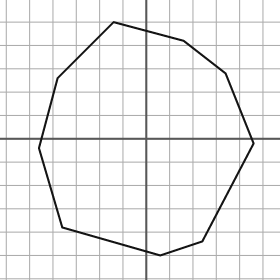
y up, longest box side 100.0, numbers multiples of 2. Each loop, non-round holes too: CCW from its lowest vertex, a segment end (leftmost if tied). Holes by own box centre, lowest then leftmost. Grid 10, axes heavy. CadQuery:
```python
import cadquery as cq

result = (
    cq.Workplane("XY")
    .moveTo(6.0, -50.0)
    .lineTo(24.0, -44.0)
    .lineTo(46.0, -2.0)
    .lineTo(34.0, 28.0)
    .lineTo(16.0, 42.0)
    .lineTo(-14.0, 50.0)
    .lineTo(-38.0, 26.0)
    .lineTo(-46.0, -4.0)
    .lineTo(-36.0, -38.0)
    .close()
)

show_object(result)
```